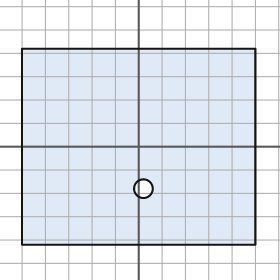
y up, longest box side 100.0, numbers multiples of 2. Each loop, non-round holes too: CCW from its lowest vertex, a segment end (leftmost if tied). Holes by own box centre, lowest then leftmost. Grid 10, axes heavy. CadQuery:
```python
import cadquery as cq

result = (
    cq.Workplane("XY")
    .moveTo(-50.0, -42.0)
    .lineTo(50.0, -42.0)
    .lineTo(50.0, 42.0)
    .lineTo(-50.0, 42.0)
    .close()
    .moveTo(2.0, -18.0)
    .circle(4.0)
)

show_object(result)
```